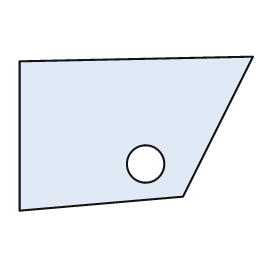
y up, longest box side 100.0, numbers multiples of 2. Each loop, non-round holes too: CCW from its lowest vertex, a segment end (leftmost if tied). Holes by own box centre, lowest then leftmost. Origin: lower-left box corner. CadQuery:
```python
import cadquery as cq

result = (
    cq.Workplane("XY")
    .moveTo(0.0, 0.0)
    .lineTo(70.0, 6.0)
    .lineTo(100.0, 66.0)
    .lineTo(0.0, 64.0)
    .close()
    .moveTo(54.0, 20.0)
    .circle(8.0)
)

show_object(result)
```